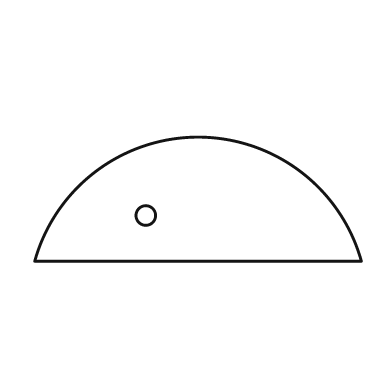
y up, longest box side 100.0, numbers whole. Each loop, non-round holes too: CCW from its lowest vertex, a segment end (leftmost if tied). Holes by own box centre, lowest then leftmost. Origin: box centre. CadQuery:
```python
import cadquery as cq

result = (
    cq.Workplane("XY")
    .moveTo(-50.0, -19.0)
    .lineTo(50.0, -19.0)
    .threePointArc((0.0, 19.0), (-50.0, -19.0))
    .close()
    .moveTo(-16.0, -5.0)
    .circle(3.0)
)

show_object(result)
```